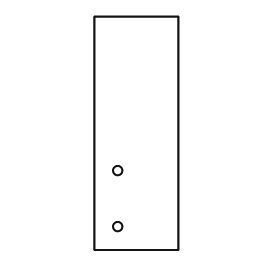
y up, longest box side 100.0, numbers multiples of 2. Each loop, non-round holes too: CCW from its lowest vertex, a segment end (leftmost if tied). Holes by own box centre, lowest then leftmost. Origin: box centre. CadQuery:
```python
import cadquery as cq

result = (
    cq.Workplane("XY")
    .moveTo(-18.0, -50.0)
    .lineTo(18.0, -50.0)
    .lineTo(18.0, 50.0)
    .lineTo(-18.0, 50.0)
    .close()
    .moveTo(-8.0, -40.0)
    .circle(2.0)
    .moveTo(-8.0, -16.0)
    .circle(2.0)
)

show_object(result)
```